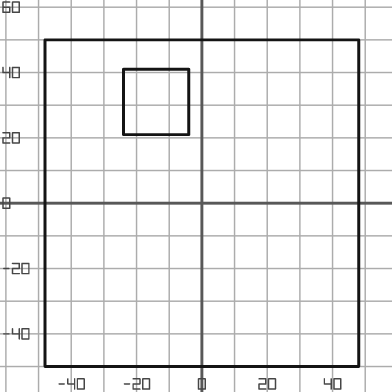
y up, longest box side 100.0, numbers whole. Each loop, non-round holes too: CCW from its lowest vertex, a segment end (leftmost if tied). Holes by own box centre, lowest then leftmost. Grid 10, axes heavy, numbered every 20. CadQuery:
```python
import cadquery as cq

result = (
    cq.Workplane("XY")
    .moveTo(-48.0, -50.0)
    .lineTo(48.0, -50.0)
    .lineTo(48.0, 50.0)
    .lineTo(-48.0, 50.0)
    .close()
    .moveTo(-24.0, 21.0)
    .lineTo(-4.0, 21.0)
    .lineTo(-4.0, 41.0)
    .lineTo(-24.0, 41.0)
    .close()
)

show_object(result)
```